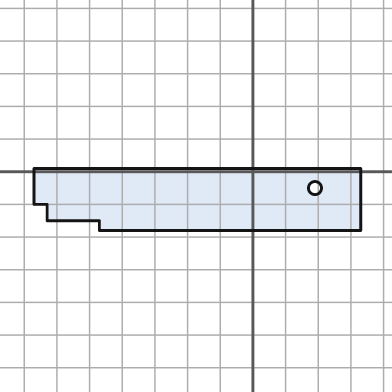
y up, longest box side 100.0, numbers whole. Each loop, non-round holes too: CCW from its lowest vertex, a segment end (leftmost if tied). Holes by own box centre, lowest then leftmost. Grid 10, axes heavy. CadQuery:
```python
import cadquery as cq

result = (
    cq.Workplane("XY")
    .moveTo(-47.0, -18.0)
    .lineTo(33.0, -18.0)
    .lineTo(33.0, 1.0)
    .lineTo(-67.0, 1.0)
    .lineTo(-67.0, -10.0)
    .lineTo(-63.0, -10.0)
    .lineTo(-63.0, -15.0)
    .lineTo(-47.0, -15.0)
    .close()
    .moveTo(19.0, -5.0)
    .circle(2.0)
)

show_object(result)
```